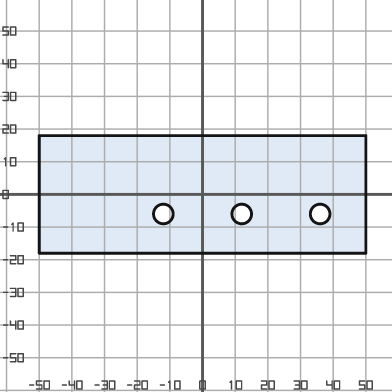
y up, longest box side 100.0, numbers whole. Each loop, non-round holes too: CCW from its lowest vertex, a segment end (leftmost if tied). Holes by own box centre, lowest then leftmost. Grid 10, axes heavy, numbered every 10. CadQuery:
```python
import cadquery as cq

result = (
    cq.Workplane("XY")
    .moveTo(-50.0, -18.0)
    .lineTo(50.0, -18.0)
    .lineTo(50.0, 18.0)
    .lineTo(-50.0, 18.0)
    .close()
    .moveTo(-12.0, -6.0)
    .circle(3.0)
    .moveTo(12.0, -6.0)
    .circle(3.0)
    .moveTo(36.0, -6.0)
    .circle(3.0)
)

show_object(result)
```